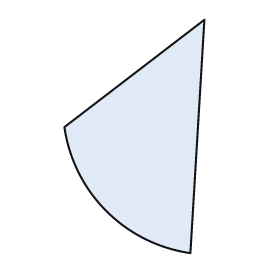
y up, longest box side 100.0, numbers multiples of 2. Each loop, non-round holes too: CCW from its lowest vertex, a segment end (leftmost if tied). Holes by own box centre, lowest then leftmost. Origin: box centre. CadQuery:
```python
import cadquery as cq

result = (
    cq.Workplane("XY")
    .moveTo(24.0, -50.0)
    .lineTo(30.0, 50.0)
    .lineTo(-30.0, 4.0)
    .threePointArc((-12.0, -32.0), (24.0, -50.0))
    .close()
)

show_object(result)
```